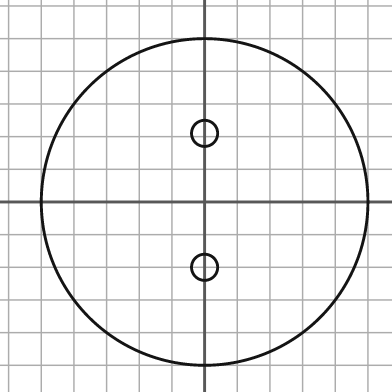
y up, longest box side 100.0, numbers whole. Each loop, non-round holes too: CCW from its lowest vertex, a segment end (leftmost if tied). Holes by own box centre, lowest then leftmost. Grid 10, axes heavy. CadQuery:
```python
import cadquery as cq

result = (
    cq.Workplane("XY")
    .moveTo(0.0, 0.0)
    .circle(50.0)
    .moveTo(0.0, -20.0)
    .circle(4.0)
    .moveTo(0.0, 21.0)
    .circle(4.0)
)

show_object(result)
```